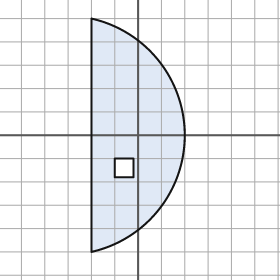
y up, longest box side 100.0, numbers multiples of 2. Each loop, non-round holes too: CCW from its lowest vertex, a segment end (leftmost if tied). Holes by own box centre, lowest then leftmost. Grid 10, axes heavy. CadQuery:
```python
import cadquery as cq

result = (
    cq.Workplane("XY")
    .moveTo(-20.0, -50.0)
    .threePointArc((20.0, 0.0), (-20.0, 50.0))
    .close()
    .moveTo(-10.0, -18.0)
    .lineTo(-2.0, -18.0)
    .lineTo(-2.0, -10.0)
    .lineTo(-10.0, -10.0)
    .close()
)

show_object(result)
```